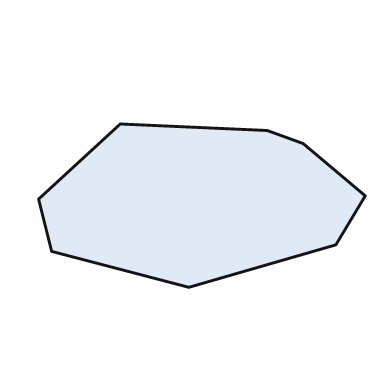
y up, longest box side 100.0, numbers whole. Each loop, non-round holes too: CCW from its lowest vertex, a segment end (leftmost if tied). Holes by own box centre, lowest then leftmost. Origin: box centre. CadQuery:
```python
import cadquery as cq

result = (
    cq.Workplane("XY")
    .moveTo(-4.0, -25.0)
    .lineTo(41.0, -12.0)
    .lineTo(50.0, 3.0)
    .lineTo(31.0, 19.0)
    .lineTo(20.0, 23.0)
    .lineTo(-25.0, 25.0)
    .lineTo(-50.0, 2.0)
    .lineTo(-46.0, -14.0)
    .close()
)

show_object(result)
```